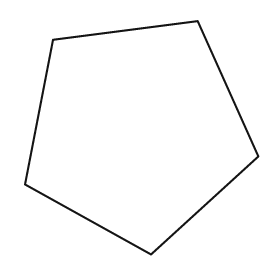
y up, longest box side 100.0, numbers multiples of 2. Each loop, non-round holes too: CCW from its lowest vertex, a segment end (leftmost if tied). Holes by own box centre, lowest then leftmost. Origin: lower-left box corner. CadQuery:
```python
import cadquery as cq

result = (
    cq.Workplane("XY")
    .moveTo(54.0, 0.0)
    .lineTo(100.0, 42.0)
    .lineTo(74.0, 100.0)
    .lineTo(12.0, 92.0)
    .lineTo(0.0, 30.0)
    .close()
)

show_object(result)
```